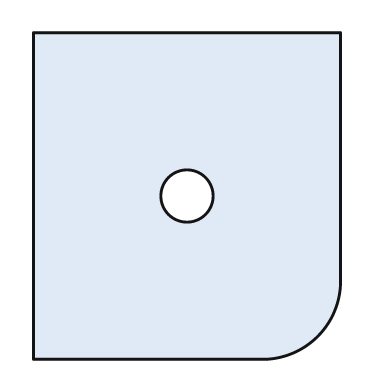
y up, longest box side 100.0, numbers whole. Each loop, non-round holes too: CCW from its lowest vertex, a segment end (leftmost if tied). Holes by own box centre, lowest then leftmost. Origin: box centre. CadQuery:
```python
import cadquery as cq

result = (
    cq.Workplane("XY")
    .moveTo(-47.0, -50.0)
    .lineTo(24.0, -50.0)
    .threePointArc((40.0, -43.0), (47.0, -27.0))
    .lineTo(47.0, 50.0)
    .lineTo(-47.0, 50.0)
    .close()
    .moveTo(0.0, 0.0)
    .circle(8.0)
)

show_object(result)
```